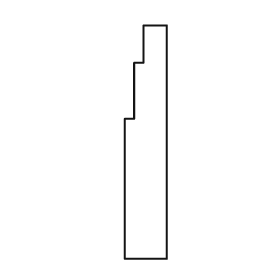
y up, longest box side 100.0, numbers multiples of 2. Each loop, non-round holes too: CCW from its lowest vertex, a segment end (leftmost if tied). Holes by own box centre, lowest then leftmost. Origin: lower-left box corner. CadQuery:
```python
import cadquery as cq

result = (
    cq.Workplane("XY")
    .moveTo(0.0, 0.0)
    .lineTo(18.0, 0.0)
    .lineTo(18.0, 100.0)
    .lineTo(8.0, 100.0)
    .lineTo(8.0, 84.0)
    .lineTo(4.0, 84.0)
    .lineTo(4.0, 60.0)
    .lineTo(0.0, 60.0)
    .close()
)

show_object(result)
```